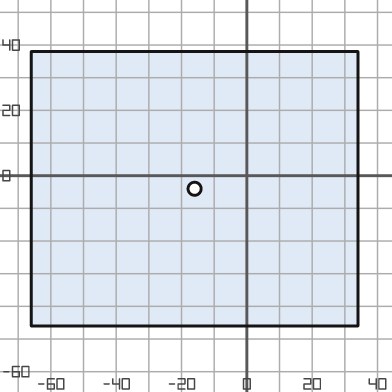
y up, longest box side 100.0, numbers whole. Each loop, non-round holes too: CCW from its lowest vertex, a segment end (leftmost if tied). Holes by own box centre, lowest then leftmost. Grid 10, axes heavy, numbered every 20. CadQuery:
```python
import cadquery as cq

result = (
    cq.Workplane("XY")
    .moveTo(-66.0, -46.0)
    .lineTo(34.0, -46.0)
    .lineTo(34.0, 38.0)
    .lineTo(-66.0, 38.0)
    .close()
    .moveTo(-16.0, -4.0)
    .circle(2.0)
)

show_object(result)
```